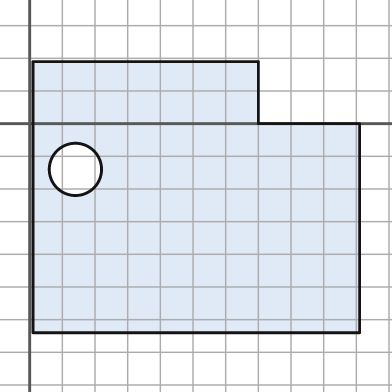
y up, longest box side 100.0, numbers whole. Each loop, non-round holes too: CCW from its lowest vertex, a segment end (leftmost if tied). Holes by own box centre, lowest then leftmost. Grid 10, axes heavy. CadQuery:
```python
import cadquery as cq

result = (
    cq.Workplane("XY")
    .moveTo(1.0, -64.0)
    .lineTo(101.0, -64.0)
    .lineTo(101.0, 0.0)
    .lineTo(70.0, 0.0)
    .lineTo(70.0, 19.0)
    .lineTo(1.0, 19.0)
    .close()
    .moveTo(14.0, -14.0)
    .circle(8.0)
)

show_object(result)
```